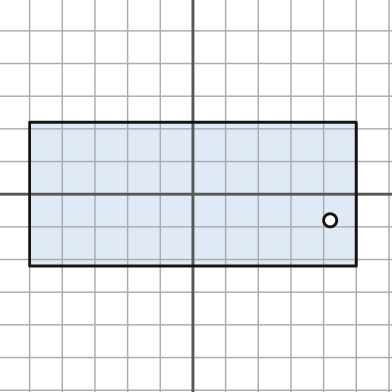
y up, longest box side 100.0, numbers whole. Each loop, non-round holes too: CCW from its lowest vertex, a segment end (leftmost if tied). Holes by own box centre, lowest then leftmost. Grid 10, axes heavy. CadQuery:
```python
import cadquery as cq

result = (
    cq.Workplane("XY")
    .moveTo(-50.0, -22.0)
    .lineTo(50.0, -22.0)
    .lineTo(50.0, 22.0)
    .lineTo(-50.0, 22.0)
    .close()
    .moveTo(42.0, -8.0)
    .circle(2.0)
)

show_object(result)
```